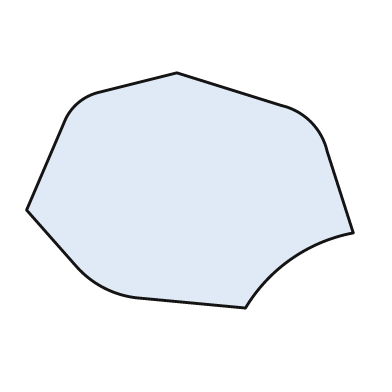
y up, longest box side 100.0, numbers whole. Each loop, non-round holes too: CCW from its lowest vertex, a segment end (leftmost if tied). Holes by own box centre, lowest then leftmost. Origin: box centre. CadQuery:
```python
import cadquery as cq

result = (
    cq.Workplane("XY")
    .moveTo(17.0, -36.0)
    .threePointArc((31.0, -21.0), (50.0, -13.0))
    .lineTo(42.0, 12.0)
    .threePointArc((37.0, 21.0), (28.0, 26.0))
    .lineTo(-4.0, 36.0)
    .lineTo(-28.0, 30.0)
    .threePointArc((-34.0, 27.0), (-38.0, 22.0))
    .lineTo(-50.0, -6.0)
    .lineTo(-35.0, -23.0)
    .threePointArc((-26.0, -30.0), (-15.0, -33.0))
    .close()
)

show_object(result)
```